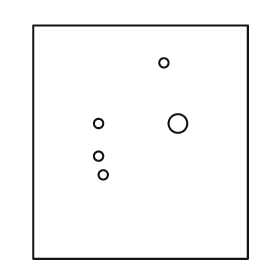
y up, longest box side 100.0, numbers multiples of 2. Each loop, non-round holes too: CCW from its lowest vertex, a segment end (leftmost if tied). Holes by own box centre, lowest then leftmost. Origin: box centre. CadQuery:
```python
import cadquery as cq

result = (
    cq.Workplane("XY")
    .moveTo(-46.0, -50.0)
    .lineTo(46.0, -50.0)
    .lineTo(46.0, 50.0)
    .lineTo(-46.0, 50.0)
    .close()
    .moveTo(-16.0, -14.0)
    .circle(2.0)
    .moveTo(-18.0, -6.0)
    .circle(2.0)
    .moveTo(-18.0, 8.0)
    .circle(2.0)
    .moveTo(16.0, 8.0)
    .circle(4.0)
    .moveTo(10.0, 34.0)
    .circle(2.0)
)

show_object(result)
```